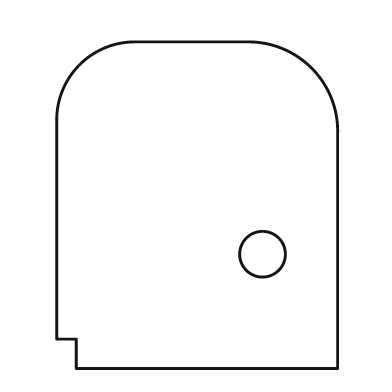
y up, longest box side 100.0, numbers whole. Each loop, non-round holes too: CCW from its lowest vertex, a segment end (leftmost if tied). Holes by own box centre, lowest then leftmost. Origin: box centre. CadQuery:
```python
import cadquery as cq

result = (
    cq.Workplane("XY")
    .moveTo(-37.0, -50.0)
    .lineTo(43.0, -50.0)
    .lineTo(43.0, 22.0)
    .threePointArc((35.0, 42.0), (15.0, 50.0))
    .lineTo(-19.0, 50.0)
    .threePointArc((-36.0, 43.0), (-43.0, 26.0))
    .lineTo(-43.0, -41.0)
    .lineTo(-37.0, -41.0)
    .close()
    .moveTo(20.0, -15.0)
    .circle(7.0)
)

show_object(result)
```